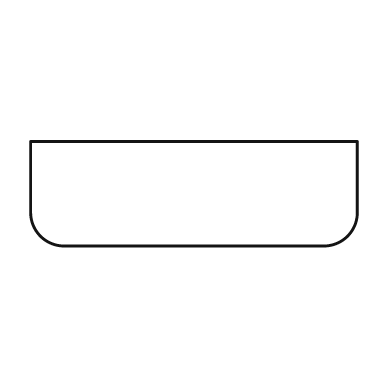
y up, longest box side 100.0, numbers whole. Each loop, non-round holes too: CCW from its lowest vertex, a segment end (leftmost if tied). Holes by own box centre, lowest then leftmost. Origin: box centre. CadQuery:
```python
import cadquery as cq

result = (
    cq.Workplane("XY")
    .moveTo(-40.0, -16.0)
    .lineTo(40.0, -16.0)
    .threePointArc((47.0, -13.0), (50.0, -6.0))
    .lineTo(50.0, 16.0)
    .lineTo(-50.0, 16.0)
    .lineTo(-50.0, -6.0)
    .threePointArc((-47.0, -13.0), (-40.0, -16.0))
    .close()
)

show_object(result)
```